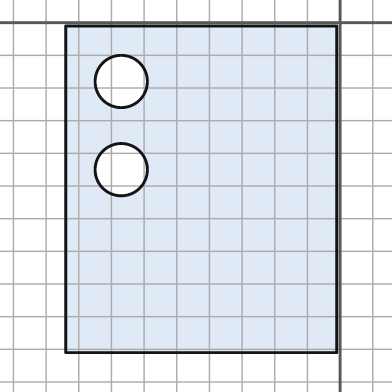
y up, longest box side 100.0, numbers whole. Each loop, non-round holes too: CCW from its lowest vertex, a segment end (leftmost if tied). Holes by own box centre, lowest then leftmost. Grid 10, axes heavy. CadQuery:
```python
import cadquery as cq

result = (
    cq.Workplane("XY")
    .moveTo(-84.0, -101.0)
    .lineTo(-1.0, -101.0)
    .lineTo(-1.0, -1.0)
    .lineTo(-84.0, -1.0)
    .close()
    .moveTo(-67.0, -45.0)
    .circle(8.0)
    .moveTo(-67.0, -18.0)
    .circle(8.0)
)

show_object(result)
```